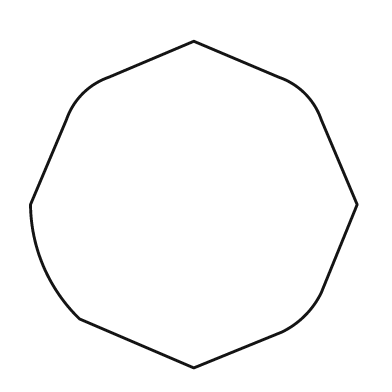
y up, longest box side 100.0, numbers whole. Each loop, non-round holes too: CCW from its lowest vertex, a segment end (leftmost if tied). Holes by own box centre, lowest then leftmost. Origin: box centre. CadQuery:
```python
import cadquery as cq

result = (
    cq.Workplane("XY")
    .moveTo(0.0, -50.0)
    .lineTo(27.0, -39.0)
    .threePointArc((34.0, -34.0), (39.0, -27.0))
    .lineTo(50.0, 0.0)
    .lineTo(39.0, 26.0)
    .threePointArc((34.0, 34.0), (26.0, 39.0))
    .lineTo(0.0, 50.0)
    .lineTo(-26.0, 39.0)
    .threePointArc((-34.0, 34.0), (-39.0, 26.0))
    .lineTo(-50.0, 0.0)
    .threePointArc((-46.0, -19.0), (-35.0, -35.0))
    .close()
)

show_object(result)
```